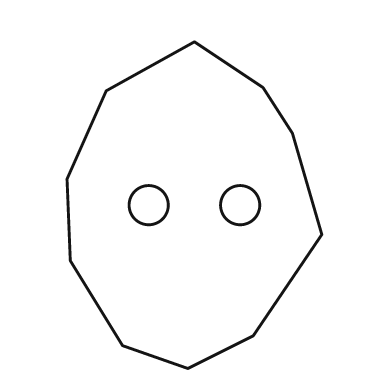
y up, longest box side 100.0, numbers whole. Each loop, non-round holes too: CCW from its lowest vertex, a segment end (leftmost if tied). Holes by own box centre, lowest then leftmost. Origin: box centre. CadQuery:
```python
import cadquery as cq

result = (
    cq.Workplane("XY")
    .moveTo(-2.0, -50.0)
    .lineTo(18.0, -40.0)
    .lineTo(39.0, -9.0)
    .lineTo(30.0, 22.0)
    .lineTo(21.0, 36.0)
    .lineTo(0.0, 50.0)
    .lineTo(-27.0, 35.0)
    .lineTo(-39.0, 8.0)
    .lineTo(-38.0, -17.0)
    .lineTo(-22.0, -43.0)
    .close()
    .moveTo(-14.0, 0.0)
    .circle(6.0)
    .moveTo(14.0, 0.0)
    .circle(6.0)
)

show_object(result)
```